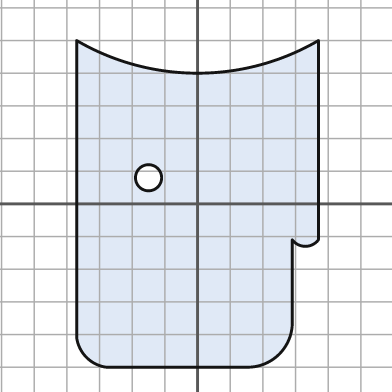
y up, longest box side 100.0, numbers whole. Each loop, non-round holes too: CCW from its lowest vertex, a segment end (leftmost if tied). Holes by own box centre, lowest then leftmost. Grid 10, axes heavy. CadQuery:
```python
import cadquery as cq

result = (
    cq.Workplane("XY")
    .moveTo(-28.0, -50.0)
    .lineTo(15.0, -50.0)
    .threePointArc((25.0, -46.0), (29.0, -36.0))
    .lineTo(29.0, -11.0)
    .threePointArc((33.0, -13.0), (37.0, -11.0))
    .lineTo(37.0, 50.0)
    .threePointArc((0.0, 40.0), (-37.0, 50.0))
    .lineTo(-37.0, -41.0)
    .threePointArc((-34.0, -47.0), (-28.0, -50.0))
    .close()
    .moveTo(-15.0, 8.0)
    .circle(4.0)
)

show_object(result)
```